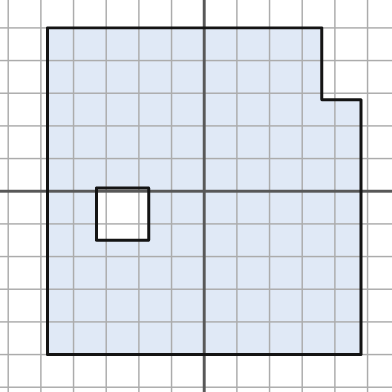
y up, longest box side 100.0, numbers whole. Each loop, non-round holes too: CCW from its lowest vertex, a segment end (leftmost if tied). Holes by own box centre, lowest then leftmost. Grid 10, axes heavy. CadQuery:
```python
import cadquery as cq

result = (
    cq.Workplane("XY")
    .moveTo(-48.0, -50.0)
    .lineTo(48.0, -50.0)
    .lineTo(48.0, 28.0)
    .lineTo(36.0, 28.0)
    .lineTo(36.0, 50.0)
    .lineTo(-48.0, 50.0)
    .close()
    .moveTo(-33.0, -15.0)
    .lineTo(-17.0, -15.0)
    .lineTo(-17.0, 1.0)
    .lineTo(-33.0, 1.0)
    .close()
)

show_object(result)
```